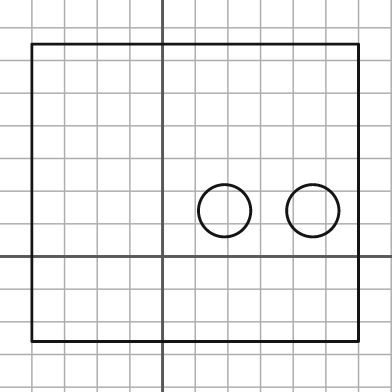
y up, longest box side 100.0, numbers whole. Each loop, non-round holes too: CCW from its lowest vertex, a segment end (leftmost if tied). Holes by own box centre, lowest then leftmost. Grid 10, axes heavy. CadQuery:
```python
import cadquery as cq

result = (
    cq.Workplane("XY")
    .moveTo(-40.0, -26.0)
    .lineTo(60.0, -26.0)
    .lineTo(60.0, 65.0)
    .lineTo(-40.0, 65.0)
    .close()
    .moveTo(19.0, 14.0)
    .circle(8.0)
    .moveTo(46.0, 14.0)
    .circle(8.0)
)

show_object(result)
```